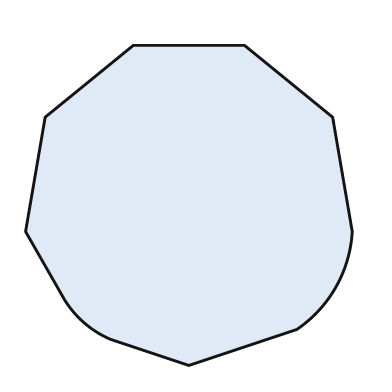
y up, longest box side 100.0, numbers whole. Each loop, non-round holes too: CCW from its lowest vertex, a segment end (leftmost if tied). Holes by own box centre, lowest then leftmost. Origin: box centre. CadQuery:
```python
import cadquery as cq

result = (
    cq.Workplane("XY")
    .moveTo(0.0, -49.0)
    .lineTo(33.0, -38.0)
    .threePointArc((45.0, -25.0), (50.0, -8.0))
    .lineTo(44.0, 27.0)
    .lineTo(17.0, 49.0)
    .lineTo(-17.0, 49.0)
    .lineTo(-44.0, 27.0)
    .lineTo(-50.0, -8.0)
    .lineTo(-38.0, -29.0)
    .threePointArc((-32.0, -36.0), (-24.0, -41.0))
    .close()
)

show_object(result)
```